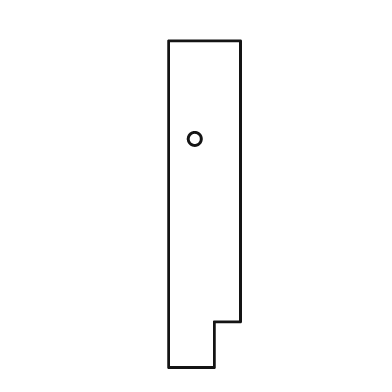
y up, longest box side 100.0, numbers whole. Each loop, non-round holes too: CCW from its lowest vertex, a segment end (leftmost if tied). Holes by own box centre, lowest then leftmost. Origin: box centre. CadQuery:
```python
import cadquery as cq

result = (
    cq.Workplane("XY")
    .moveTo(-11.0, -50.0)
    .lineTo(3.0, -50.0)
    .lineTo(3.0, -36.0)
    .lineTo(11.0, -36.0)
    .lineTo(11.0, 50.0)
    .lineTo(-11.0, 50.0)
    .close()
    .moveTo(-3.0, 20.0)
    .circle(2.0)
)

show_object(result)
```